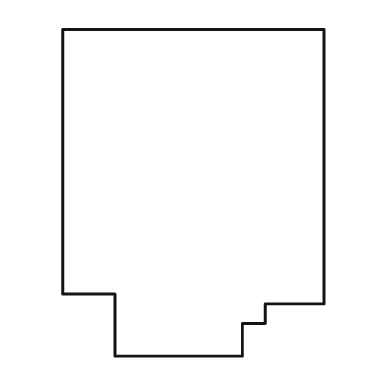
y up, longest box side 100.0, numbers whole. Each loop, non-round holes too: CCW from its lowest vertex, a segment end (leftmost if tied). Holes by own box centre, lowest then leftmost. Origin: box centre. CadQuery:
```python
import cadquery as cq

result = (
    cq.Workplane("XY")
    .moveTo(-24.0, -50.0)
    .lineTo(15.0, -50.0)
    .lineTo(15.0, -40.0)
    .lineTo(22.0, -40.0)
    .lineTo(22.0, -34.0)
    .lineTo(40.0, -34.0)
    .lineTo(40.0, 50.0)
    .lineTo(-40.0, 50.0)
    .lineTo(-40.0, -31.0)
    .lineTo(-24.0, -31.0)
    .close()
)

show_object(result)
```